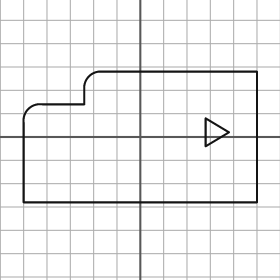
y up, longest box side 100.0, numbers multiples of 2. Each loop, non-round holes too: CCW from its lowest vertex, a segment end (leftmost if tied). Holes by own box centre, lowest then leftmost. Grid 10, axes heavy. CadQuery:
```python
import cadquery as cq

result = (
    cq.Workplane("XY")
    .moveTo(-50.0, -28.0)
    .lineTo(50.0, -28.0)
    .lineTo(50.0, 28.0)
    .lineTo(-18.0, 28.0)
    .threePointArc((-22.0, 26.0), (-24.0, 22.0))
    .lineTo(-24.0, 14.0)
    .lineTo(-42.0, 14.0)
    .threePointArc((-48.0, 12.0), (-50.0, 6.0))
    .close()
    .moveTo(28.0, -4.0)
    .lineTo(38.0, 2.0)
    .lineTo(28.0, 8.0)
    .close()
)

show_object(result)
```